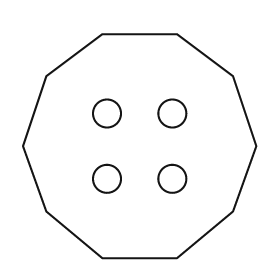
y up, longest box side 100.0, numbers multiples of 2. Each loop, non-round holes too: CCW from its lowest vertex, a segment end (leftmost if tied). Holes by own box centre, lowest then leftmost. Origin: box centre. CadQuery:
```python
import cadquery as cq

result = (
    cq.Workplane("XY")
    .moveTo(-16.0, -48.0)
    .lineTo(16.0, -48.0)
    .lineTo(40.0, -28.0)
    .lineTo(50.0, 0.0)
    .lineTo(40.0, 30.0)
    .lineTo(16.0, 48.0)
    .lineTo(-16.0, 48.0)
    .lineTo(-40.0, 30.0)
    .lineTo(-50.0, 0.0)
    .lineTo(-40.0, -28.0)
    .close()
    .moveTo(-14.0, -14.0)
    .circle(6.0)
    .moveTo(14.0, -14.0)
    .circle(6.0)
    .moveTo(-14.0, 14.0)
    .circle(6.0)
    .moveTo(14.0, 14.0)
    .circle(6.0)
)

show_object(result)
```